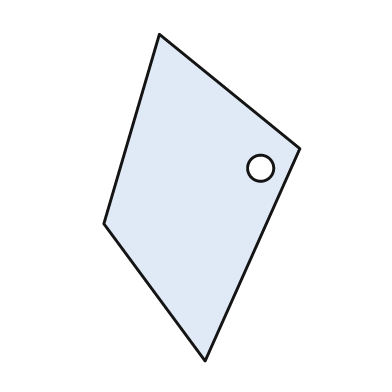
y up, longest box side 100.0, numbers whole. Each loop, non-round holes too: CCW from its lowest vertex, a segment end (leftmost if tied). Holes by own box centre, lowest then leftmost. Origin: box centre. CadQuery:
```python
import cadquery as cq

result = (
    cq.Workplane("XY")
    .moveTo(1.0, -50.0)
    .lineTo(30.0, 15.0)
    .lineTo(-13.0, 50.0)
    .lineTo(-30.0, -8.0)
    .close()
    .moveTo(18.0, 9.0)
    .circle(4.0)
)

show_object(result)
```